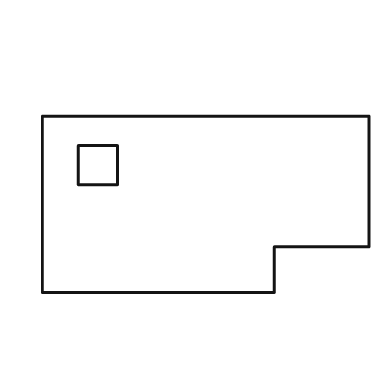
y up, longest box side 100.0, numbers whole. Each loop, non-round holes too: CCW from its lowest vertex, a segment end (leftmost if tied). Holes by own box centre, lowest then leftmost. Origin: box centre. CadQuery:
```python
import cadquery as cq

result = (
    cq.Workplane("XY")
    .moveTo(-50.0, -27.0)
    .lineTo(21.0, -27.0)
    .lineTo(21.0, -13.0)
    .lineTo(50.0, -13.0)
    .lineTo(50.0, 27.0)
    .lineTo(-50.0, 27.0)
    .close()
    .moveTo(-39.0, 6.0)
    .lineTo(-27.0, 6.0)
    .lineTo(-27.0, 18.0)
    .lineTo(-39.0, 18.0)
    .close()
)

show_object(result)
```